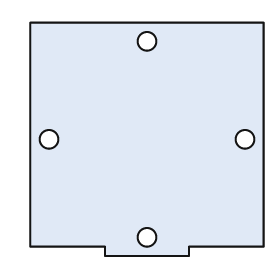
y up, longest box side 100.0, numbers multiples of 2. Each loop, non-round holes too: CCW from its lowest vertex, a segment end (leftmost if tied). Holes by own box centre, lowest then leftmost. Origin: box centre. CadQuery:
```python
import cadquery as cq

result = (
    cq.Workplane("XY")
    .moveTo(-18.0, -50.0)
    .lineTo(18.0, -50.0)
    .lineTo(18.0, -46.0)
    .lineTo(50.0, -46.0)
    .lineTo(50.0, 50.0)
    .lineTo(-50.0, 50.0)
    .lineTo(-50.0, -46.0)
    .lineTo(-18.0, -46.0)
    .close()
    .moveTo(0.0, -42.0)
    .circle(4.0)
    .moveTo(-42.0, 0.0)
    .circle(4.0)
    .moveTo(42.0, 0.0)
    .circle(4.0)
    .moveTo(0.0, 42.0)
    .circle(4.0)
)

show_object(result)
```